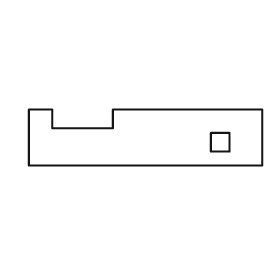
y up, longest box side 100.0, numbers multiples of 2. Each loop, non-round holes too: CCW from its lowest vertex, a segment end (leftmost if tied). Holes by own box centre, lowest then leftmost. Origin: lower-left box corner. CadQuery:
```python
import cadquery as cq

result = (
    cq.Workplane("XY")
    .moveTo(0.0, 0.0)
    .lineTo(100.0, 0.0)
    .lineTo(100.0, 24.0)
    .lineTo(36.0, 24.0)
    .lineTo(36.0, 16.0)
    .lineTo(10.0, 16.0)
    .lineTo(10.0, 24.0)
    .lineTo(0.0, 24.0)
    .close()
    .moveTo(78.0, 6.0)
    .lineTo(86.0, 6.0)
    .lineTo(86.0, 14.0)
    .lineTo(78.0, 14.0)
    .close()
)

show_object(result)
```